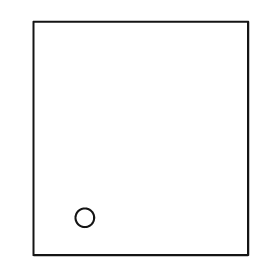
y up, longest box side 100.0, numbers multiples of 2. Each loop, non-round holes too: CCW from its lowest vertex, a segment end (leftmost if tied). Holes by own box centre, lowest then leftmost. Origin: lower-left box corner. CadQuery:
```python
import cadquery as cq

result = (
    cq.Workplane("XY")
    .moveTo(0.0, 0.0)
    .lineTo(92.0, 0.0)
    .lineTo(92.0, 100.0)
    .lineTo(0.0, 100.0)
    .close()
    .moveTo(22.0, 16.0)
    .circle(4.0)
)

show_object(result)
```